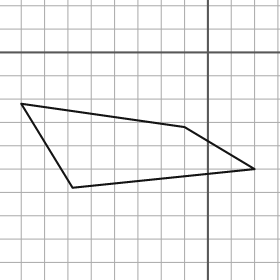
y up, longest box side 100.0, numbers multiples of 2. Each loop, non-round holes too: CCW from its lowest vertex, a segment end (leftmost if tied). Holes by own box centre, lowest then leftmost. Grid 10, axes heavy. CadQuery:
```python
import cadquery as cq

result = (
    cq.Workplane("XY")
    .moveTo(-58.0, -58.0)
    .lineTo(20.0, -50.0)
    .lineTo(-10.0, -32.0)
    .lineTo(-80.0, -22.0)
    .close()
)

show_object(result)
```